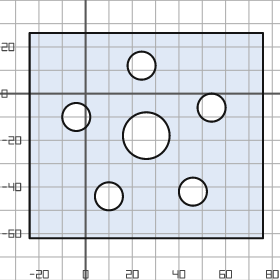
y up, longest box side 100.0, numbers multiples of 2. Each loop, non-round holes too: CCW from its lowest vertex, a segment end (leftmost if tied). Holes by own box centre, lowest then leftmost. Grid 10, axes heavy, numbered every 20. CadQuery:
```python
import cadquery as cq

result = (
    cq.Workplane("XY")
    .moveTo(-24.0, -62.0)
    .lineTo(76.0, -62.0)
    .lineTo(76.0, 26.0)
    .lineTo(-24.0, 26.0)
    .close()
    .moveTo(10.0, -44.0)
    .circle(6.0)
    .moveTo(46.0, -42.0)
    .circle(6.0)
    .moveTo(26.0, -18.0)
    .circle(10.0)
    .moveTo(-4.0, -10.0)
    .circle(6.0)
    .moveTo(54.0, -6.0)
    .circle(6.0)
    .moveTo(24.0, 12.0)
    .circle(6.0)
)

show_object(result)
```